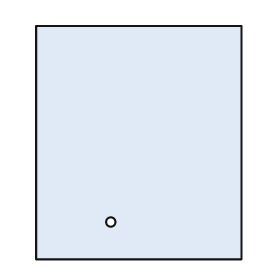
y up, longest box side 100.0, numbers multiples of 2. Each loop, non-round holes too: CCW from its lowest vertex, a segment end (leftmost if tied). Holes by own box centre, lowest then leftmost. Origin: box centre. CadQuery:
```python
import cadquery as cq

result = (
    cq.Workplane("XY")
    .moveTo(-44.0, -50.0)
    .lineTo(44.0, -50.0)
    .lineTo(44.0, 50.0)
    .lineTo(-44.0, 50.0)
    .close()
    .moveTo(-12.0, -34.0)
    .circle(2.0)
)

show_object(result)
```